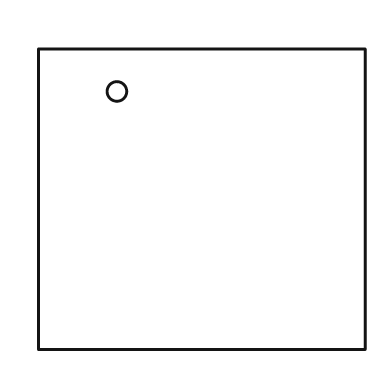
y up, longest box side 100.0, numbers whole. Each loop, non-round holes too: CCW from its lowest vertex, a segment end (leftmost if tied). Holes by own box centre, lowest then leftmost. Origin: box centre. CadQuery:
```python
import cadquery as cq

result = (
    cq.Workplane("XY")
    .moveTo(-50.0, -46.0)
    .lineTo(50.0, -46.0)
    .lineTo(50.0, 46.0)
    .lineTo(-50.0, 46.0)
    .close()
    .moveTo(-26.0, 33.0)
    .circle(3.0)
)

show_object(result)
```